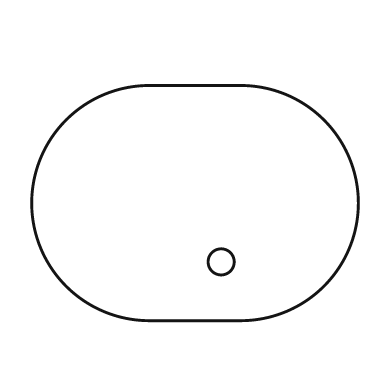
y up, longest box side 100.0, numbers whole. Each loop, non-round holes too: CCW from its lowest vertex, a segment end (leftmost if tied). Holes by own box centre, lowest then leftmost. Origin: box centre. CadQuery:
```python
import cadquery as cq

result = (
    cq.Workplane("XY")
    .moveTo(-14.0, -36.0)
    .lineTo(14.0, -36.0)
    .threePointArc((50.0, 0.0), (14.0, 36.0))
    .lineTo(-14.0, 36.0)
    .threePointArc((-50.0, 0.0), (-14.0, -36.0))
    .close()
    .moveTo(8.0, -18.0)
    .circle(4.0)
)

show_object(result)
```